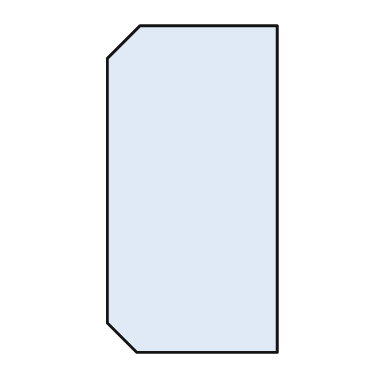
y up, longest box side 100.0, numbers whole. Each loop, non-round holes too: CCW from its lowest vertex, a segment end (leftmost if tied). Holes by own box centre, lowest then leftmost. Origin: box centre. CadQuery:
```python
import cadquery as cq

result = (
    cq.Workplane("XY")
    .moveTo(-17.0, -50.0)
    .lineTo(26.0, -50.0)
    .lineTo(26.0, 50.0)
    .lineTo(-16.0, 50.0)
    .lineTo(-26.0, 40.0)
    .lineTo(-26.0, -41.0)
    .close()
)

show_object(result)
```